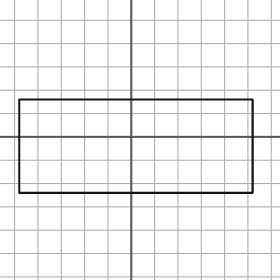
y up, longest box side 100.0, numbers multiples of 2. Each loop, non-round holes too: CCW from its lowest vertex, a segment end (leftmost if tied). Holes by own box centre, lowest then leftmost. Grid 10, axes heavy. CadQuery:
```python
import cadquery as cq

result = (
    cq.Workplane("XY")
    .moveTo(-48.0, -24.0)
    .lineTo(52.0, -24.0)
    .lineTo(52.0, 16.0)
    .lineTo(-48.0, 16.0)
    .close()
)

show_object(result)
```